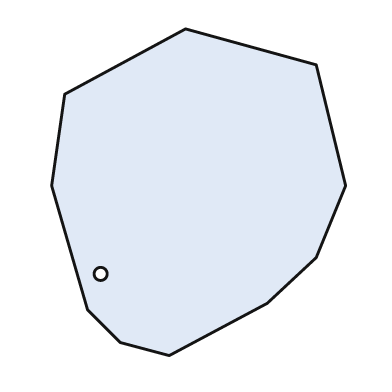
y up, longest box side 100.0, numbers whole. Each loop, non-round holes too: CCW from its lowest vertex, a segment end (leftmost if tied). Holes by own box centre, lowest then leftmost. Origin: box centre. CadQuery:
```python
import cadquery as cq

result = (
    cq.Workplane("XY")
    .moveTo(-9.0, -50.0)
    .lineTo(21.0, -34.0)
    .lineTo(36.0, -20.0)
    .lineTo(45.0, 2.0)
    .lineTo(36.0, 39.0)
    .lineTo(-4.0, 50.0)
    .lineTo(-41.0, 30.0)
    .lineTo(-45.0, 2.0)
    .lineTo(-34.0, -36.0)
    .lineTo(-24.0, -46.0)
    .close()
    .moveTo(-30.0, -25.0)
    .circle(2.0)
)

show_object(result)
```